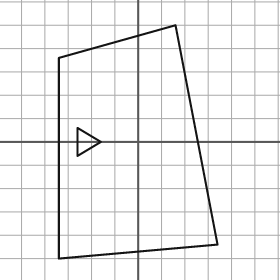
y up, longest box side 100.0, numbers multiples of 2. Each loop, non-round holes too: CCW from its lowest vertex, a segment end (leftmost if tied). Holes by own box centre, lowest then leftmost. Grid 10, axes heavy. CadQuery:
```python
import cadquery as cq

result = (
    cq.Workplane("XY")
    .moveTo(-34.0, -50.0)
    .lineTo(34.0, -44.0)
    .lineTo(16.0, 50.0)
    .lineTo(-34.0, 36.0)
    .close()
    .moveTo(-26.0, -6.0)
    .lineTo(-16.0, 0.0)
    .lineTo(-26.0, 6.0)
    .close()
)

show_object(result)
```